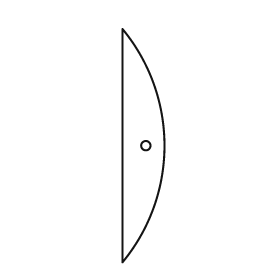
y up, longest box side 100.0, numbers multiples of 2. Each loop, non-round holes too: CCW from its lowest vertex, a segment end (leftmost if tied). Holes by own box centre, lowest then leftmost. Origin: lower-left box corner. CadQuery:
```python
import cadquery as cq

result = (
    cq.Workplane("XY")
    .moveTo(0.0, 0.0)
    .threePointArc((18.0, 50.0), (0.0, 100.0))
    .close()
    .moveTo(10.0, 50.0)
    .circle(2.0)
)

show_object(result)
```